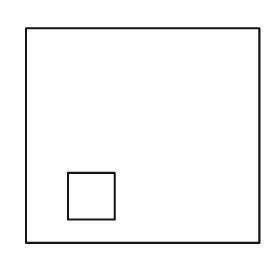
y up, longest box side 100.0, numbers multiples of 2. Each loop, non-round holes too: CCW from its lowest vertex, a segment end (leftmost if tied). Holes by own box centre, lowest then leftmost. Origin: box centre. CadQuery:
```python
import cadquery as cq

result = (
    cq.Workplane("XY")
    .moveTo(-50.0, -46.0)
    .lineTo(50.0, -46.0)
    .lineTo(50.0, 46.0)
    .lineTo(-50.0, 46.0)
    .close()
    .moveTo(-32.0, -36.0)
    .lineTo(-12.0, -36.0)
    .lineTo(-12.0, -16.0)
    .lineTo(-32.0, -16.0)
    .close()
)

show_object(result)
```